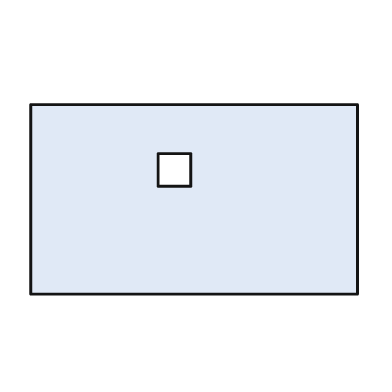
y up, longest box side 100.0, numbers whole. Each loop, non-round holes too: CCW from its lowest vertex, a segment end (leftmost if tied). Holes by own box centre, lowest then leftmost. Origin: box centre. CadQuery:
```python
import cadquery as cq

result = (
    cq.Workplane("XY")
    .moveTo(-50.0, -29.0)
    .lineTo(50.0, -29.0)
    .lineTo(50.0, 29.0)
    .lineTo(-50.0, 29.0)
    .close()
    .moveTo(-11.0, 4.0)
    .lineTo(-1.0, 4.0)
    .lineTo(-1.0, 14.0)
    .lineTo(-11.0, 14.0)
    .close()
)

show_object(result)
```